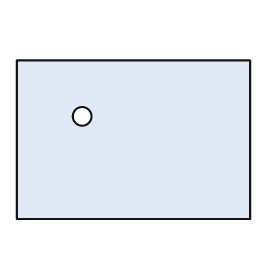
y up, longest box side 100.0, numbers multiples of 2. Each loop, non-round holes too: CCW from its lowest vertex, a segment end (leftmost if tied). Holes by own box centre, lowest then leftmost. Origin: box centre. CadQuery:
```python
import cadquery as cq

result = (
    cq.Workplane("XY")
    .moveTo(-50.0, -34.0)
    .lineTo(50.0, -34.0)
    .lineTo(50.0, 34.0)
    .lineTo(-50.0, 34.0)
    .close()
    .moveTo(-22.0, 10.0)
    .circle(4.0)
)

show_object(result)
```